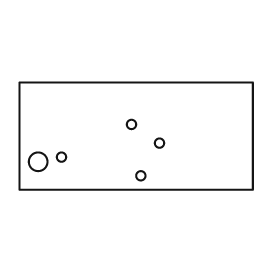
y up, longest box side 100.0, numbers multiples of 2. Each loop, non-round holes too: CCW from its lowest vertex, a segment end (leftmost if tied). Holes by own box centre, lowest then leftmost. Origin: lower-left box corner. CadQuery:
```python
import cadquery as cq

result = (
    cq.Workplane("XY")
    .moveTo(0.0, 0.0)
    .lineTo(100.0, 0.0)
    .lineTo(100.0, 46.0)
    .lineTo(0.0, 46.0)
    .close()
    .moveTo(52.0, 6.0)
    .circle(2.0)
    .moveTo(8.0, 12.0)
    .circle(4.0)
    .moveTo(18.0, 14.0)
    .circle(2.0)
    .moveTo(60.0, 20.0)
    .circle(2.0)
    .moveTo(48.0, 28.0)
    .circle(2.0)
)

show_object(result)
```